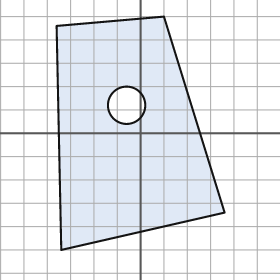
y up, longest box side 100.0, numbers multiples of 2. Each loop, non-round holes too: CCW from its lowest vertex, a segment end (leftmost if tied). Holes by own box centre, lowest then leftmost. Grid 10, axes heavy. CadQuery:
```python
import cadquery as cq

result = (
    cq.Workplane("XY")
    .moveTo(-34.0, -50.0)
    .lineTo(36.0, -34.0)
    .lineTo(10.0, 50.0)
    .lineTo(-36.0, 46.0)
    .close()
    .moveTo(-6.0, 12.0)
    .circle(8.0)
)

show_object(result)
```